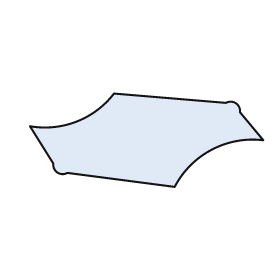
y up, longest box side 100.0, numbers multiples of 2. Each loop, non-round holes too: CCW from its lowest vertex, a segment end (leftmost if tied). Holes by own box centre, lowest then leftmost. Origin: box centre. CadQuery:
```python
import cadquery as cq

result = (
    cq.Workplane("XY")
    .moveTo(12.0, -20.0)
    .threePointArc((28.0, -4.0), (50.0, 0.0))
    .lineTo(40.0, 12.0)
    .threePointArc((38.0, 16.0), (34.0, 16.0))
    .lineTo(-14.0, 20.0)
    .threePointArc((-30.0, 8.0), (-50.0, 6.0))
    .lineTo(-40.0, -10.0)
    .threePointArc((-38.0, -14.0), (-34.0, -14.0))
    .close()
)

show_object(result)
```